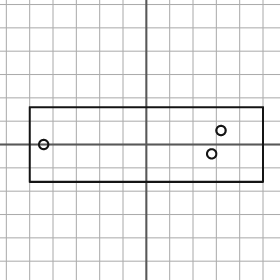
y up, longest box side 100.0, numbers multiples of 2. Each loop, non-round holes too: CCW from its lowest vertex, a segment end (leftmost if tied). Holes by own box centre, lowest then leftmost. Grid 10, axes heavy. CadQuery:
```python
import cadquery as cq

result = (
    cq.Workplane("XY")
    .moveTo(-50.0, -16.0)
    .lineTo(50.0, -16.0)
    .lineTo(50.0, 16.0)
    .lineTo(-50.0, 16.0)
    .close()
    .moveTo(28.0, -4.0)
    .circle(2.0)
    .moveTo(-44.0, 0.0)
    .circle(2.0)
    .moveTo(32.0, 6.0)
    .circle(2.0)
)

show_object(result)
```